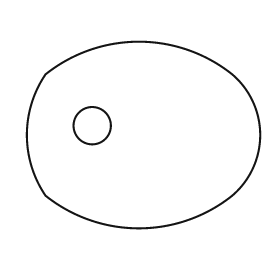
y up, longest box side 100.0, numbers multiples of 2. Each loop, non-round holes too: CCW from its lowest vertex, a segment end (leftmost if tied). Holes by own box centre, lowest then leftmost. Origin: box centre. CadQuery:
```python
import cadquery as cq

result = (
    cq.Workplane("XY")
    .moveTo(-42.0, -26.0)
    .threePointArc((-2.0, -40.0), (38.0, -26.0))
    .threePointArc((50.0, 0.0), (38.0, 26.0))
    .threePointArc((-2.0, 40.0), (-42.0, 26.0))
    .threePointArc((-50.0, 0.0), (-42.0, -26.0))
    .close()
    .moveTo(-22.0, 4.0)
    .circle(8.0)
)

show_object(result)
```